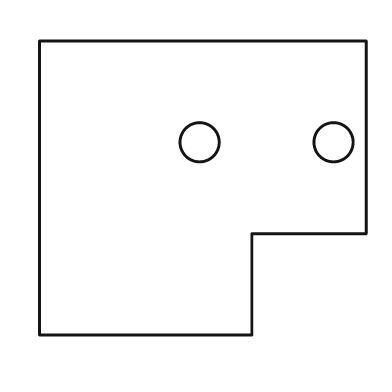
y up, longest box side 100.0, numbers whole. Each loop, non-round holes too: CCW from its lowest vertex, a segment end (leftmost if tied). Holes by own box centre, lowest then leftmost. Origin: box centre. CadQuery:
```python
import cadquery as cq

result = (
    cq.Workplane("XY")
    .moveTo(-50.0, -45.0)
    .lineTo(15.0, -45.0)
    .lineTo(15.0, -14.0)
    .lineTo(50.0, -14.0)
    .lineTo(50.0, 45.0)
    .lineTo(-50.0, 45.0)
    .close()
    .moveTo(-1.0, 14.0)
    .circle(6.0)
    .moveTo(40.0, 14.0)
    .circle(6.0)
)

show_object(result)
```